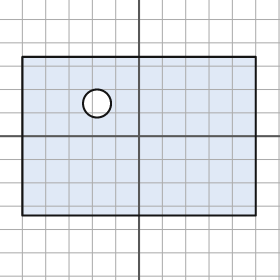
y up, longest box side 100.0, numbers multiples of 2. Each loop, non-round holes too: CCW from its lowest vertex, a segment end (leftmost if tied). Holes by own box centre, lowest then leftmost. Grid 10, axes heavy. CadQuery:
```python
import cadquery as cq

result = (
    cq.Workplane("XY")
    .moveTo(-50.0, -34.0)
    .lineTo(50.0, -34.0)
    .lineTo(50.0, 34.0)
    .lineTo(-50.0, 34.0)
    .close()
    .moveTo(-18.0, 14.0)
    .circle(6.0)
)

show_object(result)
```